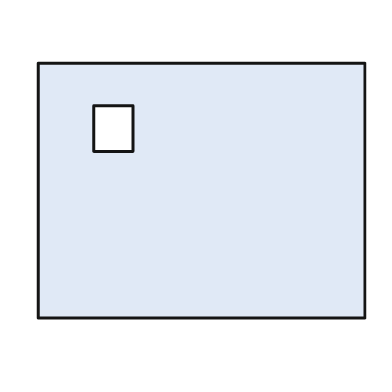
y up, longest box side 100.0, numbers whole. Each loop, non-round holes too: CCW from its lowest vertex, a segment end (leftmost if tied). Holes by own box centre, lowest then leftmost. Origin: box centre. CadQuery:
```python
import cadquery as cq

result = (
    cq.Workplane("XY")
    .moveTo(-50.0, -39.0)
    .lineTo(50.0, -39.0)
    .lineTo(50.0, 39.0)
    .lineTo(-50.0, 39.0)
    .close()
    .moveTo(-33.0, 12.0)
    .lineTo(-21.0, 12.0)
    .lineTo(-21.0, 26.0)
    .lineTo(-33.0, 26.0)
    .close()
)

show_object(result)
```